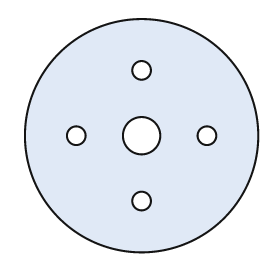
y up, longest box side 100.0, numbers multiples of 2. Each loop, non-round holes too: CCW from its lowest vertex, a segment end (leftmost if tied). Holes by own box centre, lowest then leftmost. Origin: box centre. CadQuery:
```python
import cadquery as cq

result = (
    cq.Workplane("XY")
    .moveTo(0.0, 0.0)
    .circle(50.0)
    .moveTo(0.0, -28.0)
    .circle(4.0)
    .moveTo(-28.0, 0.0)
    .circle(4.0)
    .moveTo(0.0, 0.0)
    .circle(8.0)
    .moveTo(28.0, 0.0)
    .circle(4.0)
    .moveTo(0.0, 28.0)
    .circle(4.0)
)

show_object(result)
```